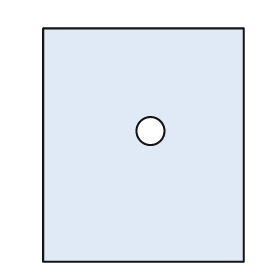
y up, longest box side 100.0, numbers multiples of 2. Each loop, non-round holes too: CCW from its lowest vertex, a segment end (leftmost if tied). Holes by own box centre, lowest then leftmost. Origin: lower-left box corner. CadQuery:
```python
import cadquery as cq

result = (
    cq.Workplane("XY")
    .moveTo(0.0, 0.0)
    .lineTo(86.0, 0.0)
    .lineTo(86.0, 100.0)
    .lineTo(0.0, 100.0)
    .close()
    .moveTo(46.0, 56.0)
    .circle(6.0)
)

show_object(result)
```